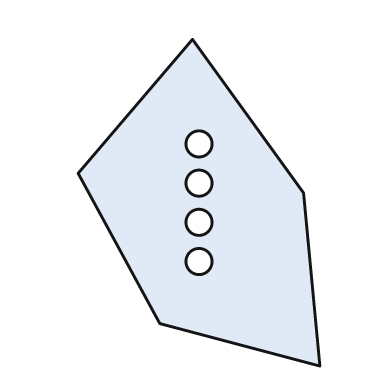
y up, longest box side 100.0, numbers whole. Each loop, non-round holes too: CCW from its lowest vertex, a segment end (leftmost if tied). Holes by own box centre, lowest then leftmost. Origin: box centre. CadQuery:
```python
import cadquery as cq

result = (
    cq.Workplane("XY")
    .moveTo(37.0, -50.0)
    .lineTo(32.0, 3.0)
    .lineTo(-2.0, 50.0)
    .lineTo(-37.0, 9.0)
    .lineTo(-12.0, -37.0)
    .close()
    .moveTo(0.0, -18.0)
    .circle(4.0)
    .moveTo(0.0, -6.0)
    .circle(4.0)
    .moveTo(0.0, 6.0)
    .circle(4.0)
    .moveTo(0.0, 18.0)
    .circle(4.0)
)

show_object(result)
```